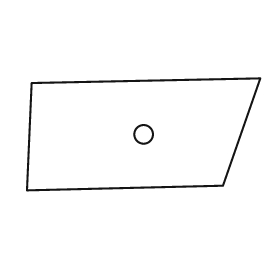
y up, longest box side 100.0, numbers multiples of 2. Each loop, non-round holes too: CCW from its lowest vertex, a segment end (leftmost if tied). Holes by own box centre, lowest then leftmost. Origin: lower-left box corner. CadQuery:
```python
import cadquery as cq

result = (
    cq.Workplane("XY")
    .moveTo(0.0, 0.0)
    .lineTo(84.0, 2.0)
    .lineTo(100.0, 48.0)
    .lineTo(2.0, 46.0)
    .close()
    .moveTo(50.0, 24.0)
    .circle(4.0)
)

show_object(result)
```